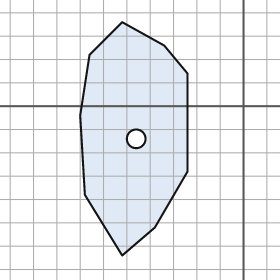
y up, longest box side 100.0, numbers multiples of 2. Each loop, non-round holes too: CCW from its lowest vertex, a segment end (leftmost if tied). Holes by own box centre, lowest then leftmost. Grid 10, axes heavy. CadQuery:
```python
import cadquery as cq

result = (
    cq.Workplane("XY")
    .moveTo(-52.0, -64.0)
    .lineTo(-38.0, -52.0)
    .lineTo(-24.0, -28.0)
    .lineTo(-24.0, 14.0)
    .lineTo(-34.0, 26.0)
    .lineTo(-52.0, 36.0)
    .lineTo(-66.0, 22.0)
    .lineTo(-70.0, -4.0)
    .lineTo(-68.0, -38.0)
    .close()
    .moveTo(-46.0, -14.0)
    .circle(4.0)
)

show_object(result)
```